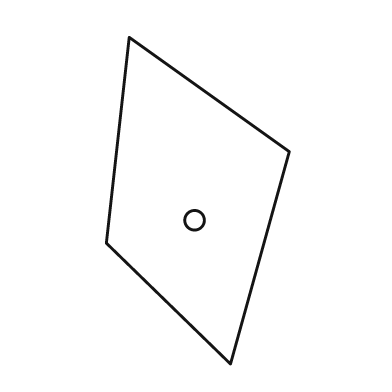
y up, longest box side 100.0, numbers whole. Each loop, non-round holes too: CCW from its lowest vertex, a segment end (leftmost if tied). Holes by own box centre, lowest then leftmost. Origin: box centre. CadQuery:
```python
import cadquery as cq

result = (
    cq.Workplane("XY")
    .moveTo(10.0, -50.0)
    .lineTo(28.0, 15.0)
    .lineTo(-21.0, 50.0)
    .lineTo(-28.0, -13.0)
    .close()
    .moveTo(-1.0, -6.0)
    .circle(3.0)
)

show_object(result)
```